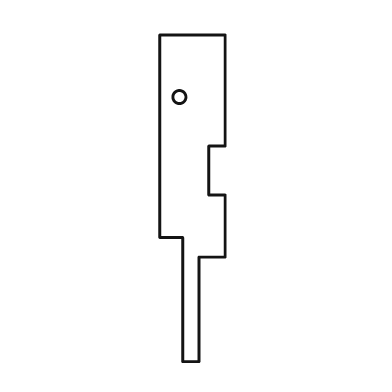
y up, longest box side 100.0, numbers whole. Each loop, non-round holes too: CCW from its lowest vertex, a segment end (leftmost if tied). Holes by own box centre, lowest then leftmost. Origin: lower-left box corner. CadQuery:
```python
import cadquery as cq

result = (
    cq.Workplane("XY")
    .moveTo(7.0, 0.0)
    .lineTo(12.0, 0.0)
    .lineTo(12.0, 32.0)
    .lineTo(20.0, 32.0)
    .lineTo(20.0, 51.0)
    .lineTo(15.0, 51.0)
    .lineTo(15.0, 66.0)
    .lineTo(20.0, 66.0)
    .lineTo(20.0, 100.0)
    .lineTo(0.0, 100.0)
    .lineTo(0.0, 38.0)
    .lineTo(7.0, 38.0)
    .close()
    .moveTo(6.0, 81.0)
    .circle(2.0)
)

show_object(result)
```